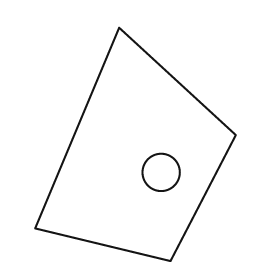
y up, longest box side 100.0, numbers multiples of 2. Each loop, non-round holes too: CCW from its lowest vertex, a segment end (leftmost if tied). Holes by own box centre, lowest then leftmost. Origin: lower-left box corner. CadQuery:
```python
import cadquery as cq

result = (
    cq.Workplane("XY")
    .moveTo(58.0, 0.0)
    .lineTo(86.0, 54.0)
    .lineTo(36.0, 100.0)
    .lineTo(0.0, 14.0)
    .close()
    .moveTo(54.0, 38.0)
    .circle(8.0)
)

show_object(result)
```